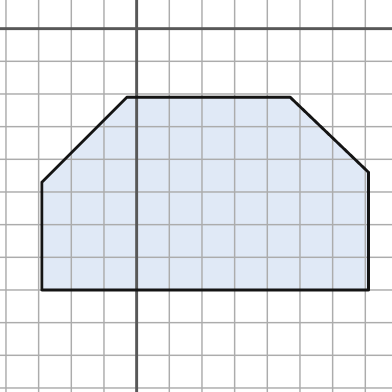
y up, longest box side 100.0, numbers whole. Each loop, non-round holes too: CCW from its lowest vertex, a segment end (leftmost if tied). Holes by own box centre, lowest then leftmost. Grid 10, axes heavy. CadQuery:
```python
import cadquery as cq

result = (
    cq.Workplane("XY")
    .moveTo(-29.0, -80.0)
    .lineTo(71.0, -80.0)
    .lineTo(71.0, -44.0)
    .lineTo(47.0, -21.0)
    .lineTo(-3.0, -21.0)
    .lineTo(-29.0, -47.0)
    .close()
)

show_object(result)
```